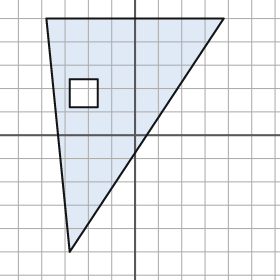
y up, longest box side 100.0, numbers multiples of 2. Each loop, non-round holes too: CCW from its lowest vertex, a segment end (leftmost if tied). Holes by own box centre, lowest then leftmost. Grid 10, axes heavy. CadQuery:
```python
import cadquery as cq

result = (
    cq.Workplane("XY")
    .moveTo(-28.0, -50.0)
    .lineTo(38.0, 50.0)
    .lineTo(-38.0, 50.0)
    .close()
    .moveTo(-28.0, 12.0)
    .lineTo(-16.0, 12.0)
    .lineTo(-16.0, 24.0)
    .lineTo(-28.0, 24.0)
    .close()
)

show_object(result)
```